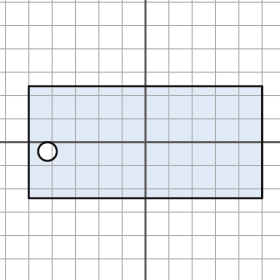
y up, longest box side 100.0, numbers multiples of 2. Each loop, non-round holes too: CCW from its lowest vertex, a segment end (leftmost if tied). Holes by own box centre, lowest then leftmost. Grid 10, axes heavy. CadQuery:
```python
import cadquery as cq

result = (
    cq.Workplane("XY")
    .moveTo(-50.0, -24.0)
    .lineTo(50.0, -24.0)
    .lineTo(50.0, 24.0)
    .lineTo(-50.0, 24.0)
    .close()
    .moveTo(-42.0, -4.0)
    .circle(4.0)
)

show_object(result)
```